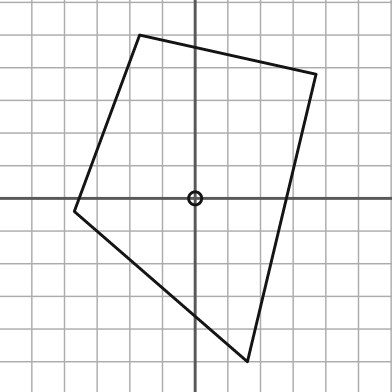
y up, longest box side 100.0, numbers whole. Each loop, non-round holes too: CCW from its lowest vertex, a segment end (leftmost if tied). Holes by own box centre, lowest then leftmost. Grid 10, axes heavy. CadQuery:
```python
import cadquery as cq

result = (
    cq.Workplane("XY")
    .moveTo(16.0, -50.0)
    .lineTo(37.0, 38.0)
    .lineTo(-17.0, 50.0)
    .lineTo(-37.0, -4.0)
    .close()
    .moveTo(0.0, 0.0)
    .circle(2.0)
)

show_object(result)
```